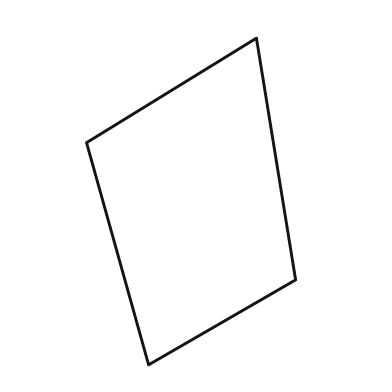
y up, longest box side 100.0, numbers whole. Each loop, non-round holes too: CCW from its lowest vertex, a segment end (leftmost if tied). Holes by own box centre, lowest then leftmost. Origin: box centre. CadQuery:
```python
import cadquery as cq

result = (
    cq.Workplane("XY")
    .moveTo(-13.0, -50.0)
    .lineTo(32.0, -24.0)
    .lineTo(20.0, 50.0)
    .lineTo(-32.0, 18.0)
    .close()
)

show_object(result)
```